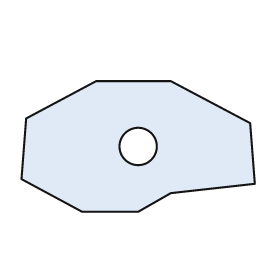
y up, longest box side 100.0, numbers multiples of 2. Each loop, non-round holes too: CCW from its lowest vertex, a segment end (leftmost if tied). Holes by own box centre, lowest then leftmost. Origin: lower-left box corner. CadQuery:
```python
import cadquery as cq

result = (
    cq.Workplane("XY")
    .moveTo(26.0, 0.0)
    .lineTo(50.0, 0.0)
    .lineTo(64.0, 8.0)
    .lineTo(100.0, 12.0)
    .lineTo(98.0, 38.0)
    .lineTo(64.0, 56.0)
    .lineTo(32.0, 56.0)
    .lineTo(2.0, 40.0)
    .lineTo(0.0, 14.0)
    .close()
    .moveTo(50.0, 28.0)
    .circle(8.0)
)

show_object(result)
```